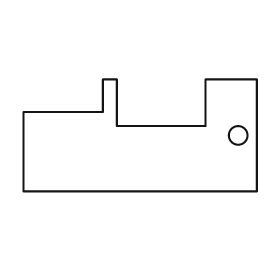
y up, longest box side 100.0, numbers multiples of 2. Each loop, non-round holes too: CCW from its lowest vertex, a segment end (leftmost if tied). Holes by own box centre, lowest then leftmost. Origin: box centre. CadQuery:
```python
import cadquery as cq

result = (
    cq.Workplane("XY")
    .moveTo(-50.0, -24.0)
    .lineTo(50.0, -24.0)
    .lineTo(50.0, 24.0)
    .lineTo(28.0, 24.0)
    .lineTo(28.0, 4.0)
    .lineTo(-10.0, 4.0)
    .lineTo(-10.0, 24.0)
    .lineTo(-16.0, 24.0)
    .lineTo(-16.0, 10.0)
    .lineTo(-50.0, 10.0)
    .close()
    .moveTo(42.0, 0.0)
    .circle(4.0)
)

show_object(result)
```